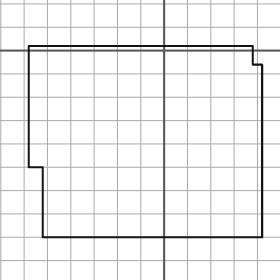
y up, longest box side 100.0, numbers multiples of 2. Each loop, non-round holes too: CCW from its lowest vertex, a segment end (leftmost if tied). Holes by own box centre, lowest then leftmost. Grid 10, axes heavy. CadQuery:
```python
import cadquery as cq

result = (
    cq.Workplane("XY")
    .moveTo(-52.0, -80.0)
    .lineTo(42.0, -80.0)
    .lineTo(42.0, -6.0)
    .lineTo(38.0, -6.0)
    .lineTo(38.0, 2.0)
    .lineTo(-58.0, 2.0)
    .lineTo(-58.0, -50.0)
    .lineTo(-52.0, -50.0)
    .close()
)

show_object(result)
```